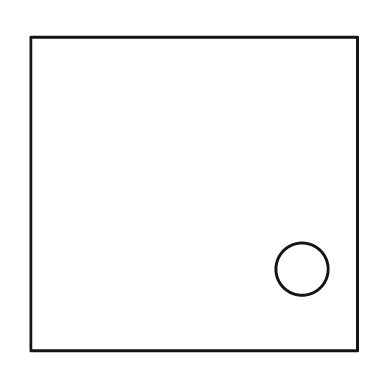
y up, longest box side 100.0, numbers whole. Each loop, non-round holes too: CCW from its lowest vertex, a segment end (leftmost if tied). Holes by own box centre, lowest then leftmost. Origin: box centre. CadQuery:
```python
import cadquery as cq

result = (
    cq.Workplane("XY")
    .moveTo(-50.0, -48.0)
    .lineTo(50.0, -48.0)
    .lineTo(50.0, 48.0)
    .lineTo(-50.0, 48.0)
    .close()
    .moveTo(33.0, -23.0)
    .circle(8.0)
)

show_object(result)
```